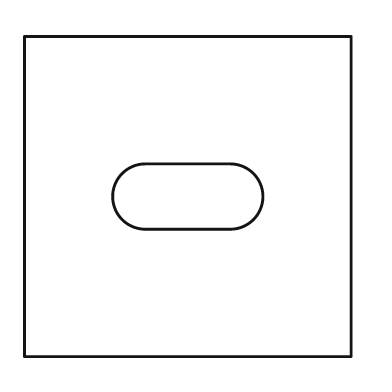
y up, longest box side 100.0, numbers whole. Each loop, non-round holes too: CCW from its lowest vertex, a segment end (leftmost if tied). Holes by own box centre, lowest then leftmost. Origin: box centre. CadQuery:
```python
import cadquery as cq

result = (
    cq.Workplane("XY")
    .moveTo(-50.0, -49.0)
    .lineTo(50.0, -49.0)
    .lineTo(50.0, 49.0)
    .lineTo(-50.0, 49.0)
    .close()
    .moveTo(-13.0, -10.0)
    .lineTo(13.0, -10.0)
    .threePointArc((23.0, 0.0), (13.0, 10.0))
    .lineTo(-13.0, 10.0)
    .threePointArc((-23.0, 0.0), (-13.0, -10.0))
    .close()
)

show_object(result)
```